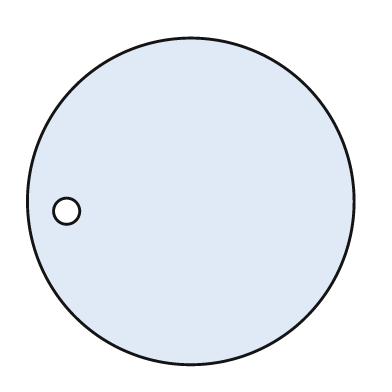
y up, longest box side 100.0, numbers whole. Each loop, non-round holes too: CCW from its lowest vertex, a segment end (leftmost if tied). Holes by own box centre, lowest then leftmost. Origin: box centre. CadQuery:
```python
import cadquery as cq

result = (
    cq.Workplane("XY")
    .moveTo(0.0, 0.0)
    .circle(50.0)
    .moveTo(-38.0, -3.0)
    .circle(4.0)
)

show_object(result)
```